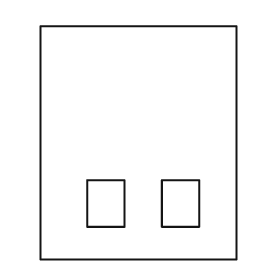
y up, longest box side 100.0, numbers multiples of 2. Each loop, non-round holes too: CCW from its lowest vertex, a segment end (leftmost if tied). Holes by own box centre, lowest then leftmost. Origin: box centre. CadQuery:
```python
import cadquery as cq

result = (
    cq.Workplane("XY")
    .moveTo(-42.0, -50.0)
    .lineTo(42.0, -50.0)
    .lineTo(42.0, 50.0)
    .lineTo(-42.0, 50.0)
    .close()
    .moveTo(-22.0, -36.0)
    .lineTo(-6.0, -36.0)
    .lineTo(-6.0, -16.0)
    .lineTo(-22.0, -16.0)
    .close()
    .moveTo(10.0, -36.0)
    .lineTo(26.0, -36.0)
    .lineTo(26.0, -16.0)
    .lineTo(10.0, -16.0)
    .close()
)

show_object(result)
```